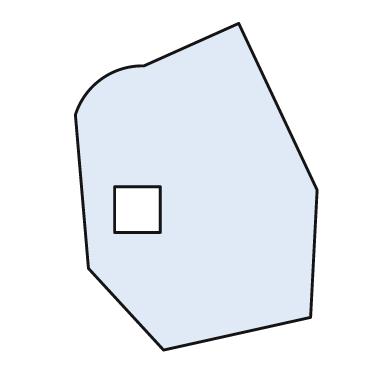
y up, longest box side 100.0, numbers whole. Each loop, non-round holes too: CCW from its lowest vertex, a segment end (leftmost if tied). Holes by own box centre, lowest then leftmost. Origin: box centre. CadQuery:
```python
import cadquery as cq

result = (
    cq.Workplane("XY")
    .moveTo(-10.0, -50.0)
    .lineTo(35.0, -40.0)
    .lineTo(37.0, -1.0)
    .lineTo(13.0, 50.0)
    .lineTo(-16.0, 37.0)
    .threePointArc((-29.0, 33.0), (-37.0, 22.0))
    .lineTo(-33.0, -25.0)
    .close()
    .moveTo(-25.0, -14.0)
    .lineTo(-11.0, -14.0)
    .lineTo(-11.0, 0.0)
    .lineTo(-25.0, 0.0)
    .close()
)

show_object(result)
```